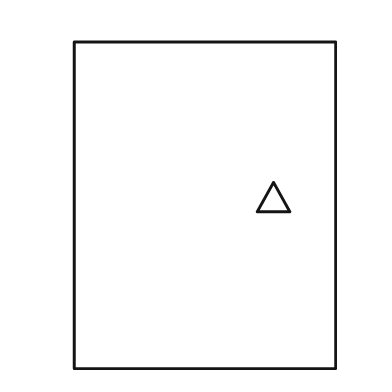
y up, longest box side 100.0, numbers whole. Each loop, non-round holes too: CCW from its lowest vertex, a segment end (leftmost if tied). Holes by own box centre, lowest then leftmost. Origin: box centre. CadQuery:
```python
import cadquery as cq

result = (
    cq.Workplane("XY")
    .moveTo(-40.0, -50.0)
    .lineTo(40.0, -50.0)
    .lineTo(40.0, 50.0)
    .lineTo(-40.0, 50.0)
    .close()
    .moveTo(16.0, -2.0)
    .lineTo(26.0, -2.0)
    .lineTo(21.0, 7.0)
    .close()
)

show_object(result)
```